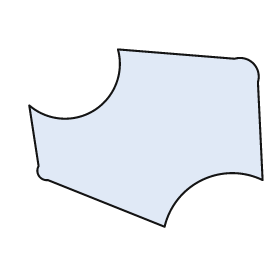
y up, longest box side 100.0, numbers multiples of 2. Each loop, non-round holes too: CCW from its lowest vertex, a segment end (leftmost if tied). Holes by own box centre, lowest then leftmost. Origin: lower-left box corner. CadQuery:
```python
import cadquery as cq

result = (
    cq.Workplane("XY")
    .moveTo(58.0, 0.0)
    .threePointArc((74.0, 20.0), (100.0, 20.0))
    .lineTo(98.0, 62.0)
    .threePointArc((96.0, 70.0), (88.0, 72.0))
    .lineTo(38.0, 76.0)
    .threePointArc((28.0, 50.0), (0.0, 52.0))
    .lineTo(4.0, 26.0)
    .threePointArc((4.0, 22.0), (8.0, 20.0))
    .close()
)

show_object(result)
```